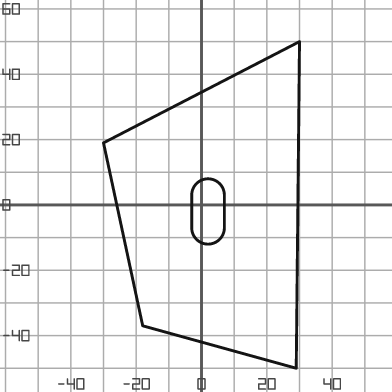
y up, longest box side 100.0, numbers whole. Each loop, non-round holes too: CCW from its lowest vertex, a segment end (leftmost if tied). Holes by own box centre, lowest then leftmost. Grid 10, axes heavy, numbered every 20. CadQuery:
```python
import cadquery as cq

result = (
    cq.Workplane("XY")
    .moveTo(29.0, -50.0)
    .lineTo(30.0, 50.0)
    .lineTo(-30.0, 19.0)
    .lineTo(-18.0, -37.0)
    .close()
    .moveTo(-3.0, -7.0)
    .threePointArc((2.0, -12.0), (7.0, -7.0))
    .lineTo(7.0, 3.0)
    .threePointArc((2.0, 8.0), (-3.0, 3.0))
    .close()
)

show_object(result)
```